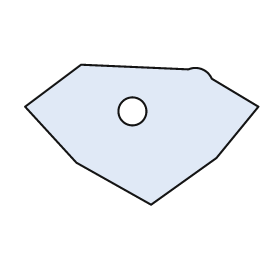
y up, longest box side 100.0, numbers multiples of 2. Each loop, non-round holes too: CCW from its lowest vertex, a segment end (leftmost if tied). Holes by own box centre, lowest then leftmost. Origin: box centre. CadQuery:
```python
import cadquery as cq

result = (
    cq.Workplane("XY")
    .moveTo(4.0, -30.0)
    .lineTo(32.0, -10.0)
    .lineTo(50.0, 12.0)
    .lineTo(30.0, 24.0)
    .threePointArc((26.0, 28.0), (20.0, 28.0))
    .lineTo(-26.0, 30.0)
    .lineTo(-50.0, 12.0)
    .lineTo(-28.0, -12.0)
    .close()
    .moveTo(-4.0, 10.0)
    .circle(6.0)
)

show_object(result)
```